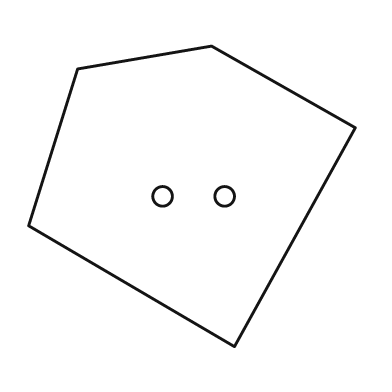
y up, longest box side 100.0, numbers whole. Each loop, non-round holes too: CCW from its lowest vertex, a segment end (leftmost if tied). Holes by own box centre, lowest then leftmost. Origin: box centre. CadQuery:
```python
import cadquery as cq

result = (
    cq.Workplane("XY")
    .moveTo(13.0, -46.0)
    .lineTo(50.0, 21.0)
    .lineTo(6.0, 46.0)
    .lineTo(-35.0, 39.0)
    .lineTo(-50.0, -9.0)
    .close()
    .moveTo(-9.0, 0.0)
    .circle(3.0)
    .moveTo(10.0, 0.0)
    .circle(3.0)
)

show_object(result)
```